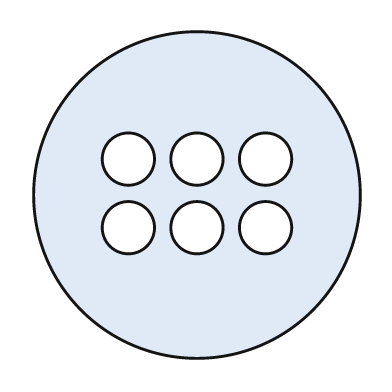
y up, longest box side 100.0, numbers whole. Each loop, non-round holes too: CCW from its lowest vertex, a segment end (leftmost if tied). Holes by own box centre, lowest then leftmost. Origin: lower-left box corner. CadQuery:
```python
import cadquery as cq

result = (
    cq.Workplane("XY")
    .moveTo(50.0, 50.0)
    .circle(50.0)
    .moveTo(29.0, 40.0)
    .circle(8.0)
    .moveTo(50.0, 40.0)
    .circle(8.0)
    .moveTo(71.0, 40.0)
    .circle(8.0)
    .moveTo(29.0, 61.0)
    .circle(8.0)
    .moveTo(50.0, 61.0)
    .circle(8.0)
    .moveTo(71.0, 61.0)
    .circle(8.0)
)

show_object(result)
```